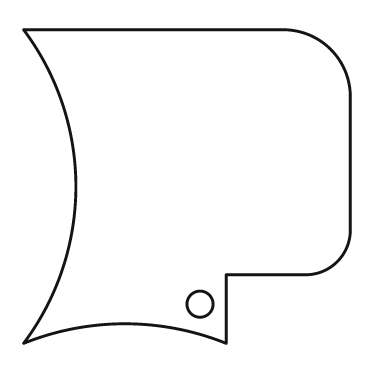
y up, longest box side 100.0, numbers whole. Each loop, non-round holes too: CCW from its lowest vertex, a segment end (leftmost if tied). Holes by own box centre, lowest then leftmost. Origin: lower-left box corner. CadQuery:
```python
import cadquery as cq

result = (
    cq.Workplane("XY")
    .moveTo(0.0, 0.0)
    .threePointArc((31.0, 6.0), (62.0, 0.0))
    .lineTo(62.0, 21.0)
    .lineTo(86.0, 21.0)
    .threePointArc((96.0, 25.0), (100.0, 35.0))
    .lineTo(100.0, 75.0)
    .threePointArc((94.0, 90.0), (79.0, 96.0))
    .lineTo(0.0, 96.0)
    .threePointArc((16.0, 48.0), (0.0, 0.0))
    .close()
    .moveTo(54.0, 12.0)
    .circle(4.0)
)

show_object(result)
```